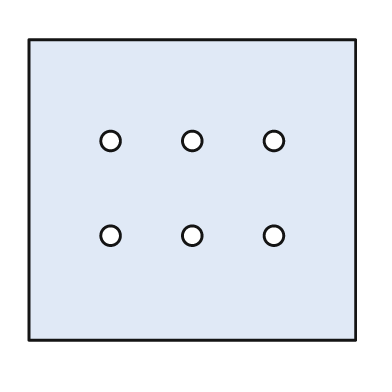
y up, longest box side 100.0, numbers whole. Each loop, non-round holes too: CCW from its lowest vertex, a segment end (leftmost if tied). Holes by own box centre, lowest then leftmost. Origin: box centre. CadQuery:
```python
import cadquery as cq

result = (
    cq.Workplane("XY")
    .moveTo(-50.0, -46.0)
    .lineTo(50.0, -46.0)
    .lineTo(50.0, 46.0)
    .lineTo(-50.0, 46.0)
    .close()
    .moveTo(-25.0, -14.0)
    .circle(3.0)
    .moveTo(0.0, -14.0)
    .circle(3.0)
    .moveTo(25.0, -14.0)
    .circle(3.0)
    .moveTo(-25.0, 15.0)
    .circle(3.0)
    .moveTo(0.0, 15.0)
    .circle(3.0)
    .moveTo(25.0, 15.0)
    .circle(3.0)
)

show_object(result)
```